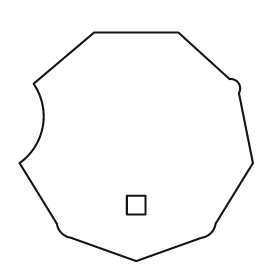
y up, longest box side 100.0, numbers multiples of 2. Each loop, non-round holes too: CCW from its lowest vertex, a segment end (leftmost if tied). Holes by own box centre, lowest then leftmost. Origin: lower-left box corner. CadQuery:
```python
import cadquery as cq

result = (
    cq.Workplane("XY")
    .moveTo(50.0, 0.0)
    .lineTo(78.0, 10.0)
    .threePointArc((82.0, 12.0), (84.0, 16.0))
    .lineTo(100.0, 42.0)
    .lineTo(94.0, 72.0)
    .threePointArc((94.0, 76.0), (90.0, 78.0))
    .lineTo(68.0, 98.0)
    .lineTo(32.0, 98.0)
    .lineTo(6.0, 76.0)
    .threePointArc((10.0, 58.0), (0.0, 42.0))
    .lineTo(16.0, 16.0)
    .threePointArc((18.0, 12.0), (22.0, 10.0))
    .close()
    .moveTo(46.0, 20.0)
    .lineTo(54.0, 20.0)
    .lineTo(54.0, 28.0)
    .lineTo(46.0, 28.0)
    .close()
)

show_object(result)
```